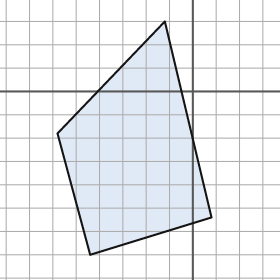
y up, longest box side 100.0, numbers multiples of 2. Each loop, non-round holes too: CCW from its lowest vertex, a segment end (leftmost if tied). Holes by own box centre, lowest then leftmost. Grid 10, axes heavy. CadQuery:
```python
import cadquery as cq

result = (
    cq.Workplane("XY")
    .moveTo(-44.0, -70.0)
    .lineTo(8.0, -54.0)
    .lineTo(-12.0, 30.0)
    .lineTo(-58.0, -18.0)
    .close()
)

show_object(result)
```